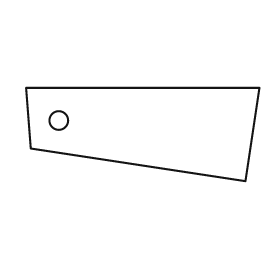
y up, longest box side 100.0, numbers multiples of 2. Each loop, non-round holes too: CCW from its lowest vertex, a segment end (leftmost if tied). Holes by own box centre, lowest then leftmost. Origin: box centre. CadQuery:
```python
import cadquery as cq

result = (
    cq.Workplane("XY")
    .moveTo(44.0, -20.0)
    .lineTo(50.0, 20.0)
    .lineTo(-50.0, 20.0)
    .lineTo(-48.0, -6.0)
    .close()
    .moveTo(-36.0, 6.0)
    .circle(4.0)
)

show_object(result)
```